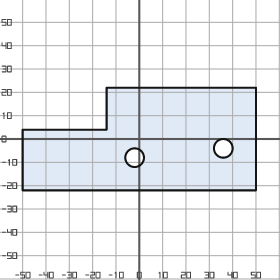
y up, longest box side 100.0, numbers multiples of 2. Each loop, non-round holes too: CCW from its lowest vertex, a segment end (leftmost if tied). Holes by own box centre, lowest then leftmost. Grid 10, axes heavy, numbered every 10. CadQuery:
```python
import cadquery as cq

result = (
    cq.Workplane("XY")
    .moveTo(-50.0, -22.0)
    .lineTo(50.0, -22.0)
    .lineTo(50.0, 22.0)
    .lineTo(-14.0, 22.0)
    .lineTo(-14.0, 4.0)
    .lineTo(-50.0, 4.0)
    .close()
    .moveTo(-2.0, -8.0)
    .circle(4.0)
    .moveTo(36.0, -4.0)
    .circle(4.0)
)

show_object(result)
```